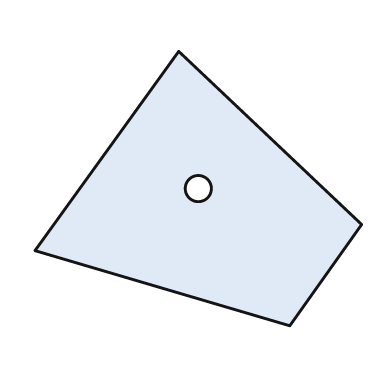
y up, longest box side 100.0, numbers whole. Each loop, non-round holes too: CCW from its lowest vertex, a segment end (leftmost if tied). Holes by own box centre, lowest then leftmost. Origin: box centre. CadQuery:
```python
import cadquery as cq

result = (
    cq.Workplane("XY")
    .moveTo(28.0, -42.0)
    .lineTo(50.0, -11.0)
    .lineTo(-6.0, 42.0)
    .lineTo(-50.0, -19.0)
    .close()
    .moveTo(0.0, 0.0)
    .circle(4.0)
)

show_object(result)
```